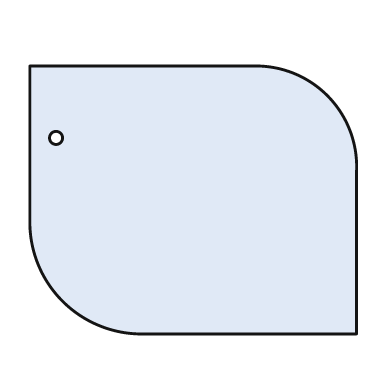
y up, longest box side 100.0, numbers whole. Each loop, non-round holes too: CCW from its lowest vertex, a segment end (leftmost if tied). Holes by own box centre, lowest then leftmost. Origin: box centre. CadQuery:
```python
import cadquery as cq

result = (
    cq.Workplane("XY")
    .moveTo(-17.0, -41.0)
    .lineTo(50.0, -41.0)
    .lineTo(50.0, 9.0)
    .threePointArc((41.0, 32.0), (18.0, 41.0))
    .lineTo(-50.0, 41.0)
    .lineTo(-50.0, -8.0)
    .threePointArc((-40.0, -31.0), (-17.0, -41.0))
    .close()
    .moveTo(-42.0, 19.0)
    .circle(2.0)
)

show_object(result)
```